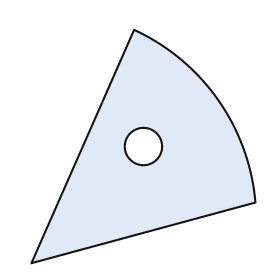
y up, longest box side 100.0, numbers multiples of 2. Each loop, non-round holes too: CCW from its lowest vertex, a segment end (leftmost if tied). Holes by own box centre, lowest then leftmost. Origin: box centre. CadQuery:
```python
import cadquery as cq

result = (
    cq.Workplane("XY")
    .moveTo(-48.0, -50.0)
    .lineTo(48.0, -24.0)
    .threePointArc((32.0, 20.0), (-4.0, 50.0))
    .close()
    .moveTo(0.0, 0.0)
    .circle(8.0)
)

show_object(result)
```